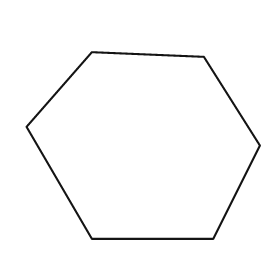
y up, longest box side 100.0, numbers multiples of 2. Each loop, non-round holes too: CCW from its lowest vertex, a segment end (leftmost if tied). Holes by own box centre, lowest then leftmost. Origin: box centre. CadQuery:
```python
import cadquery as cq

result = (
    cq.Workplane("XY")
    .moveTo(-22.0, -40.0)
    .lineTo(30.0, -40.0)
    .lineTo(50.0, 0.0)
    .lineTo(26.0, 38.0)
    .lineTo(-22.0, 40.0)
    .lineTo(-50.0, 8.0)
    .close()
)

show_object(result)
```